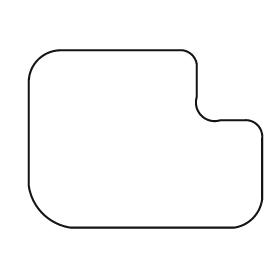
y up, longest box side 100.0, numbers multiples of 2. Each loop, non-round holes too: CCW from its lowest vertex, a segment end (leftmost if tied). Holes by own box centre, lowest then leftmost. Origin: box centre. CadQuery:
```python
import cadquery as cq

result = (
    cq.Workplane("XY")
    .moveTo(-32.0, -38.0)
    .lineTo(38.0, -38.0)
    .threePointArc((46.0, -34.0), (50.0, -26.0))
    .lineTo(50.0, 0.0)
    .threePointArc((48.0, 6.0), (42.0, 8.0))
    .lineTo(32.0, 8.0)
    .threePointArc((24.0, 10.0), (22.0, 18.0))
    .lineTo(22.0, 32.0)
    .threePointArc((20.0, 36.0), (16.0, 38.0))
    .lineTo(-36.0, 38.0)
    .threePointArc((-46.0, 34.0), (-50.0, 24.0))
    .lineTo(-50.0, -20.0)
    .threePointArc((-44.0, -32.0), (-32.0, -38.0))
    .close()
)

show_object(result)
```